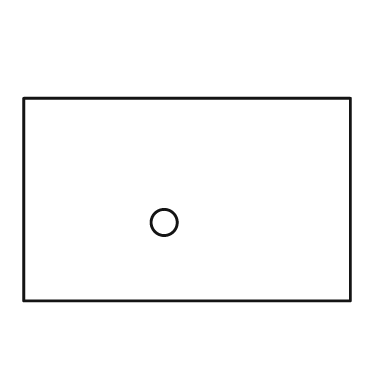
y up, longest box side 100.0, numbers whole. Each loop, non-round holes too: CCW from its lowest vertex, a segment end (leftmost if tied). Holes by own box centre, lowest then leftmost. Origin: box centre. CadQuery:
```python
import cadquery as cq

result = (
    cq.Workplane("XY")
    .moveTo(-50.0, -31.0)
    .lineTo(50.0, -31.0)
    .lineTo(50.0, 31.0)
    .lineTo(-50.0, 31.0)
    .close()
    .moveTo(-7.0, -7.0)
    .circle(4.0)
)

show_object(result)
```